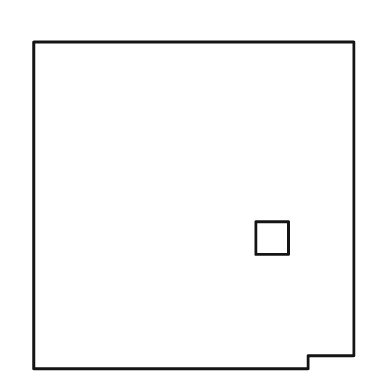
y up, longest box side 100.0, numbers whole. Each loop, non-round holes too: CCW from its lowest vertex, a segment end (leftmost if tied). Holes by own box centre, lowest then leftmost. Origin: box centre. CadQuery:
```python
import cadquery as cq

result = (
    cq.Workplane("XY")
    .moveTo(-49.0, -50.0)
    .lineTo(35.0, -50.0)
    .lineTo(35.0, -46.0)
    .lineTo(49.0, -46.0)
    .lineTo(49.0, 50.0)
    .lineTo(-49.0, 50.0)
    .close()
    .moveTo(19.0, -15.0)
    .lineTo(29.0, -15.0)
    .lineTo(29.0, -5.0)
    .lineTo(19.0, -5.0)
    .close()
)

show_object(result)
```